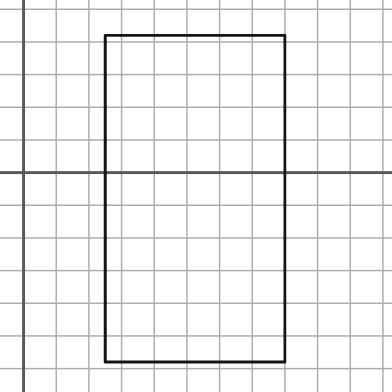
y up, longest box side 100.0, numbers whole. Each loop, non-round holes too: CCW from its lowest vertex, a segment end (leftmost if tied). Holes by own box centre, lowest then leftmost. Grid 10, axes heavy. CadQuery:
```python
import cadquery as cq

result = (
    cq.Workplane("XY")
    .moveTo(25.0, -58.0)
    .lineTo(80.0, -58.0)
    .lineTo(80.0, 42.0)
    .lineTo(25.0, 42.0)
    .close()
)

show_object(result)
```